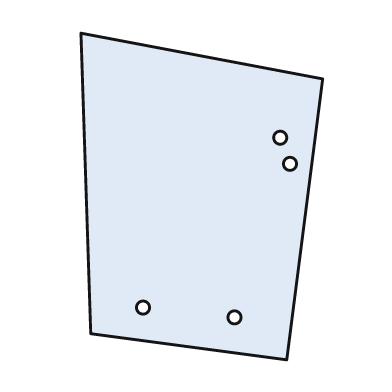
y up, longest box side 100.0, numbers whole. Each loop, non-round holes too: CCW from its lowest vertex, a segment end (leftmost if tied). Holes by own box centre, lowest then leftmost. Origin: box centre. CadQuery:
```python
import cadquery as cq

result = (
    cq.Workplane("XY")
    .moveTo(26.0, -50.0)
    .lineTo(37.0, 36.0)
    .lineTo(-37.0, 50.0)
    .lineTo(-34.0, -42.0)
    .close()
    .moveTo(10.0, -37.0)
    .circle(2.0)
    .moveTo(-18.0, -34.0)
    .circle(2.0)
    .moveTo(27.0, 10.0)
    .circle(2.0)
    .moveTo(24.0, 18.0)
    .circle(2.0)
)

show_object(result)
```